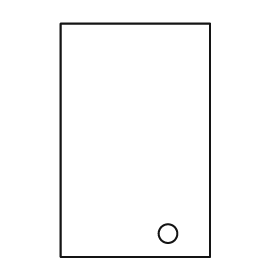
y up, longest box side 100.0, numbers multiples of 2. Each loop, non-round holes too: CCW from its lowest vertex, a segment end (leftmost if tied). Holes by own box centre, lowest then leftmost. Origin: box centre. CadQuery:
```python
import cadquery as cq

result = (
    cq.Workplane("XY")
    .moveTo(-32.0, -50.0)
    .lineTo(32.0, -50.0)
    .lineTo(32.0, 50.0)
    .lineTo(-32.0, 50.0)
    .close()
    .moveTo(14.0, -40.0)
    .circle(4.0)
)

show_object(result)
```